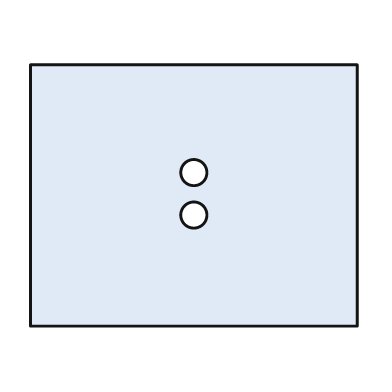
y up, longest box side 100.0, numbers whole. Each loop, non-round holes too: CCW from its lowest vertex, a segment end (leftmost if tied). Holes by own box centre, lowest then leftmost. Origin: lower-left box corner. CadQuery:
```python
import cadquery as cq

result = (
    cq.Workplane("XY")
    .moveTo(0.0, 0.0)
    .lineTo(100.0, 0.0)
    .lineTo(100.0, 80.0)
    .lineTo(0.0, 80.0)
    .close()
    .moveTo(50.0, 34.0)
    .circle(4.0)
    .moveTo(50.0, 47.0)
    .circle(4.0)
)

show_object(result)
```